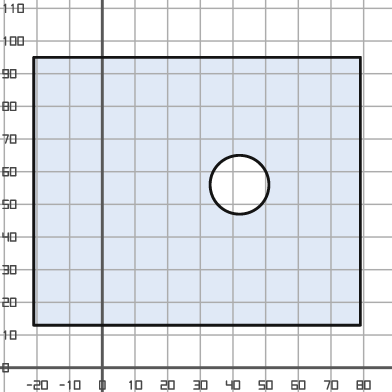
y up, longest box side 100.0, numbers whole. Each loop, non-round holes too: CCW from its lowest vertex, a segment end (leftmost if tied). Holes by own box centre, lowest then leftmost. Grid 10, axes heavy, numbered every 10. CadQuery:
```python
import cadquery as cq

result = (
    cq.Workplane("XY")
    .moveTo(-21.0, 13.0)
    .lineTo(79.0, 13.0)
    .lineTo(79.0, 95.0)
    .lineTo(-21.0, 95.0)
    .close()
    .moveTo(42.0, 56.0)
    .circle(9.0)
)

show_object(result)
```